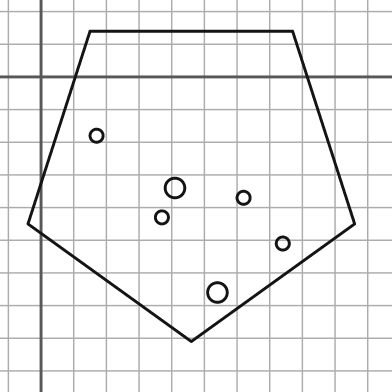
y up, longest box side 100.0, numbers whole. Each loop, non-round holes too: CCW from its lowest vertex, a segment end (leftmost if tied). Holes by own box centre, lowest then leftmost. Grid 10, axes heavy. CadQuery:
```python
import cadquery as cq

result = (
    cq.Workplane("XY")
    .moveTo(46.0, -81.0)
    .lineTo(96.0, -45.0)
    .lineTo(77.0, 14.0)
    .lineTo(15.0, 14.0)
    .lineTo(-4.0, -45.0)
    .close()
    .moveTo(54.0, -66.0)
    .circle(3.0)
    .moveTo(74.0, -51.0)
    .circle(2.0)
    .moveTo(37.0, -43.0)
    .circle(2.0)
    .moveTo(62.0, -37.0)
    .circle(2.0)
    .moveTo(41.0, -34.0)
    .circle(3.0)
    .moveTo(17.0, -18.0)
    .circle(2.0)
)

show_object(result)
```